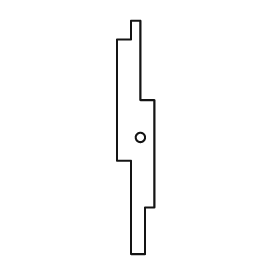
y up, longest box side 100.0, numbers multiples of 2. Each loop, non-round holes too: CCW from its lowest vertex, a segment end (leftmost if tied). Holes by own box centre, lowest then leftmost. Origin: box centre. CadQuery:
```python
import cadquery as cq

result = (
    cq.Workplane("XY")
    .moveTo(-2.0, -50.0)
    .lineTo(4.0, -50.0)
    .lineTo(4.0, -30.0)
    .lineTo(8.0, -30.0)
    .lineTo(8.0, 16.0)
    .lineTo(2.0, 16.0)
    .lineTo(2.0, 50.0)
    .lineTo(-2.0, 50.0)
    .lineTo(-2.0, 42.0)
    .lineTo(-8.0, 42.0)
    .lineTo(-8.0, -10.0)
    .lineTo(-2.0, -10.0)
    .close()
    .moveTo(2.0, 0.0)
    .circle(2.0)
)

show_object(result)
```